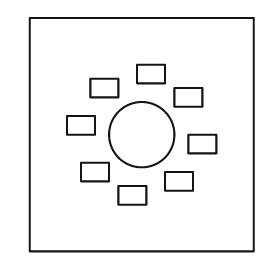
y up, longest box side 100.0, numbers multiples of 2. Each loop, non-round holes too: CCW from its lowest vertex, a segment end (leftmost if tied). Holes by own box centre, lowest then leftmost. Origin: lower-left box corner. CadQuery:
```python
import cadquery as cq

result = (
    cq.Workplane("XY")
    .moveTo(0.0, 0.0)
    .lineTo(96.0, 0.0)
    .lineTo(96.0, 100.0)
    .lineTo(0.0, 100.0)
    .close()
    .moveTo(38.0, 20.0)
    .lineTo(50.0, 20.0)
    .lineTo(50.0, 28.0)
    .lineTo(38.0, 28.0)
    .close()
    .moveTo(58.0, 26.0)
    .lineTo(70.0, 26.0)
    .lineTo(70.0, 34.0)
    .lineTo(58.0, 34.0)
    .close()
    .moveTo(22.0, 30.0)
    .lineTo(34.0, 30.0)
    .lineTo(34.0, 38.0)
    .lineTo(22.0, 38.0)
    .close()
    .moveTo(68.0, 42.0)
    .lineTo(80.0, 42.0)
    .lineTo(80.0, 50.0)
    .lineTo(68.0, 50.0)
    .close()
    .moveTo(48.0, 50.0)
    .circle(14.0)
    .moveTo(16.0, 50.0)
    .lineTo(28.0, 50.0)
    .lineTo(28.0, 58.0)
    .lineTo(16.0, 58.0)
    .close()
    .moveTo(62.0, 62.0)
    .lineTo(74.0, 62.0)
    .lineTo(74.0, 70.0)
    .lineTo(62.0, 70.0)
    .close()
    .moveTo(26.0, 66.0)
    .lineTo(38.0, 66.0)
    .lineTo(38.0, 74.0)
    .lineTo(26.0, 74.0)
    .close()
    .moveTo(46.0, 72.0)
    .lineTo(58.0, 72.0)
    .lineTo(58.0, 80.0)
    .lineTo(46.0, 80.0)
    .close()
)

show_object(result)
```